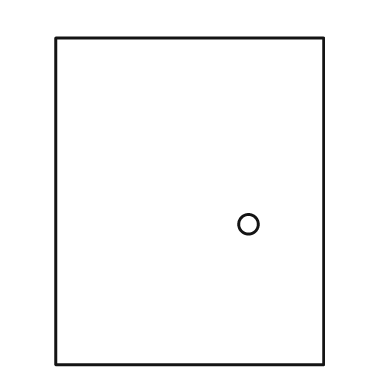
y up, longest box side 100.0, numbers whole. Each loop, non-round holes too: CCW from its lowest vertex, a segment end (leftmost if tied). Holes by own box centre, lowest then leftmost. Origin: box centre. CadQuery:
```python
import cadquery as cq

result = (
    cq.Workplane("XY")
    .moveTo(-41.0, -50.0)
    .lineTo(41.0, -50.0)
    .lineTo(41.0, 50.0)
    .lineTo(-41.0, 50.0)
    .close()
    .moveTo(18.0, -7.0)
    .circle(3.0)
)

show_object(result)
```